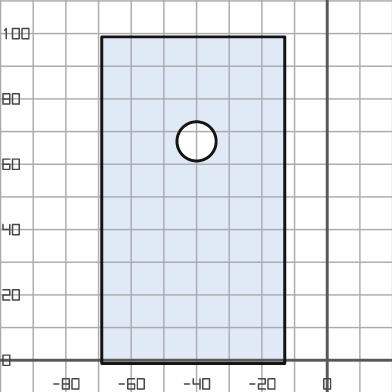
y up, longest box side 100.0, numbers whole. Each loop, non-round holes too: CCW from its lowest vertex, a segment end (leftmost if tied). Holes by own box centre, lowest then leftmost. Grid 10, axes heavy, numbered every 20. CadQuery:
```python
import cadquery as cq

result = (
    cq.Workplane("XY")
    .moveTo(-69.0, -1.0)
    .lineTo(-13.0, -1.0)
    .lineTo(-13.0, 99.0)
    .lineTo(-69.0, 99.0)
    .close()
    .moveTo(-40.0, 67.0)
    .circle(6.0)
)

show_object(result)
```